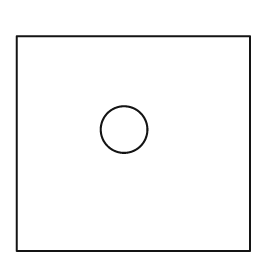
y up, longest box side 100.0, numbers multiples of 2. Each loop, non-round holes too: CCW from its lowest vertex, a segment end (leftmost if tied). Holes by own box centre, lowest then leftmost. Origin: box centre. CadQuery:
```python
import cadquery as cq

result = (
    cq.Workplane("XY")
    .moveTo(-50.0, -46.0)
    .lineTo(50.0, -46.0)
    .lineTo(50.0, 46.0)
    .lineTo(-50.0, 46.0)
    .close()
    .moveTo(-4.0, 6.0)
    .circle(10.0)
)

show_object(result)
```